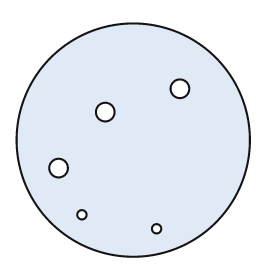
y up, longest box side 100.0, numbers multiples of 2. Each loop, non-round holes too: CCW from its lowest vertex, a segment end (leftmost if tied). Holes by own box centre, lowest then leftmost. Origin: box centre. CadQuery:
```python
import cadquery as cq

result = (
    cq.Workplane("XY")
    .moveTo(0.0, 0.0)
    .circle(50.0)
    .moveTo(10.0, -38.0)
    .circle(2.0)
    .moveTo(-22.0, -32.0)
    .circle(2.0)
    .moveTo(-32.0, -12.0)
    .circle(4.0)
    .moveTo(-12.0, 12.0)
    .circle(4.0)
    .moveTo(20.0, 22.0)
    .circle(4.0)
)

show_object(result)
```